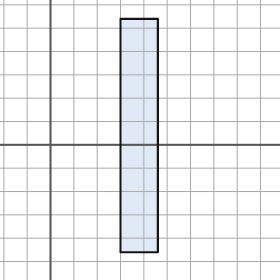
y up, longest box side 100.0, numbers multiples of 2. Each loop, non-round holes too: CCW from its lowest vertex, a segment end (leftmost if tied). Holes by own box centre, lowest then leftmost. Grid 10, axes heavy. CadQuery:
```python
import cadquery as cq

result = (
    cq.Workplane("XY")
    .moveTo(30.0, -46.0)
    .lineTo(46.0, -46.0)
    .lineTo(46.0, 54.0)
    .lineTo(30.0, 54.0)
    .close()
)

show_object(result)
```